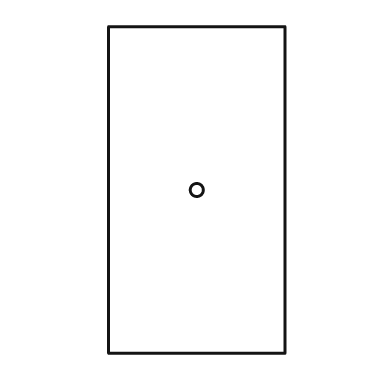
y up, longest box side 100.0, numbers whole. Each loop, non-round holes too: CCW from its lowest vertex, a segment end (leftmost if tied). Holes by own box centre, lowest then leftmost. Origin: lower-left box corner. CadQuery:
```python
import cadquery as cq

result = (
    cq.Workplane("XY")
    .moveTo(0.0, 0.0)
    .lineTo(54.0, 0.0)
    .lineTo(54.0, 100.0)
    .lineTo(0.0, 100.0)
    .close()
    .moveTo(27.0, 50.0)
    .circle(2.0)
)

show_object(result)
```